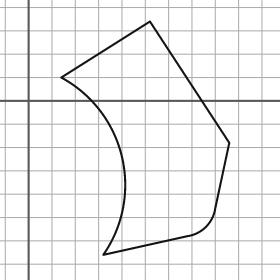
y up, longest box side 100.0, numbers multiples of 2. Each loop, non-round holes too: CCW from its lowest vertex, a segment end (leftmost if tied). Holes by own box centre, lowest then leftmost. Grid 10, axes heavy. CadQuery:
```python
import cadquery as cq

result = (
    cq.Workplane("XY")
    .moveTo(32.0, -66.0)
    .lineTo(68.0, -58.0)
    .threePointArc((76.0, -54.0), (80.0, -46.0))
    .lineTo(86.0, -18.0)
    .lineTo(52.0, 34.0)
    .lineTo(14.0, 10.0)
    .threePointArc((40.0, -24.0), (32.0, -66.0))
    .close()
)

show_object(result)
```